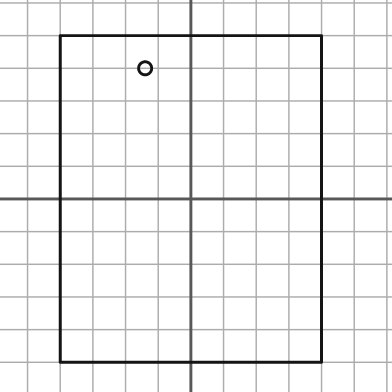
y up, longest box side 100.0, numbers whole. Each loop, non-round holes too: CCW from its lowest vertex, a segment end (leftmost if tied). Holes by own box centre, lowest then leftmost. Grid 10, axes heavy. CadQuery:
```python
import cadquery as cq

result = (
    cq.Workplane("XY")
    .moveTo(-40.0, -50.0)
    .lineTo(40.0, -50.0)
    .lineTo(40.0, 50.0)
    .lineTo(-40.0, 50.0)
    .close()
    .moveTo(-14.0, 40.0)
    .circle(2.0)
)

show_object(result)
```